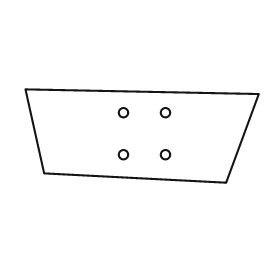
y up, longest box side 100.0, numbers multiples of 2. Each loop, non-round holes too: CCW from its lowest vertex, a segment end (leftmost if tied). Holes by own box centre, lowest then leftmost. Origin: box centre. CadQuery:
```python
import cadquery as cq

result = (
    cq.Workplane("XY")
    .moveTo(36.0, -20.0)
    .lineTo(50.0, 18.0)
    .lineTo(-50.0, 20.0)
    .lineTo(-42.0, -16.0)
    .close()
    .moveTo(-8.0, -8.0)
    .circle(2.0)
    .moveTo(10.0, -8.0)
    .circle(2.0)
    .moveTo(-8.0, 10.0)
    .circle(2.0)
    .moveTo(10.0, 10.0)
    .circle(2.0)
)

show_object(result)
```